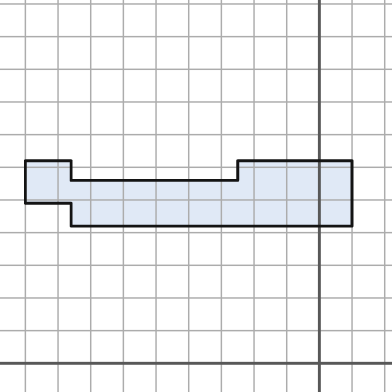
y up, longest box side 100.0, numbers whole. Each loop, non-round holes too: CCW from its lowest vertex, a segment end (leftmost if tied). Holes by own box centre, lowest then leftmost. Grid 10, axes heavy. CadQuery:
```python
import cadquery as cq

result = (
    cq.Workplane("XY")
    .moveTo(-76.0, 42.0)
    .lineTo(10.0, 42.0)
    .lineTo(10.0, 62.0)
    .lineTo(-25.0, 62.0)
    .lineTo(-25.0, 56.0)
    .lineTo(-76.0, 56.0)
    .lineTo(-76.0, 62.0)
    .lineTo(-90.0, 62.0)
    .lineTo(-90.0, 49.0)
    .lineTo(-76.0, 49.0)
    .close()
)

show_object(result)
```